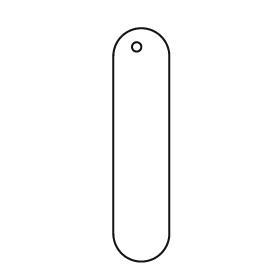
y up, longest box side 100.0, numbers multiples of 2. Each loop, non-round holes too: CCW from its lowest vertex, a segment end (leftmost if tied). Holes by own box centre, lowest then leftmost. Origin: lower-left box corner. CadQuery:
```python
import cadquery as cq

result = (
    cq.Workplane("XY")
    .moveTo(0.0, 12.0)
    .threePointArc((12.0, 0.0), (24.0, 12.0))
    .lineTo(24.0, 88.0)
    .threePointArc((12.0, 100.0), (0.0, 88.0))
    .close()
    .moveTo(10.0, 92.0)
    .circle(2.0)
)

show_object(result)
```